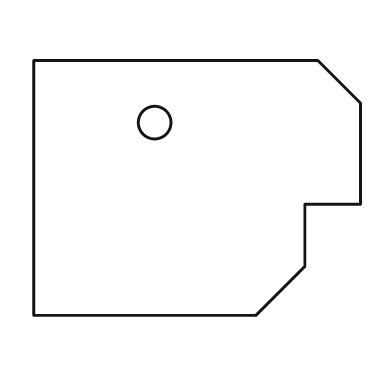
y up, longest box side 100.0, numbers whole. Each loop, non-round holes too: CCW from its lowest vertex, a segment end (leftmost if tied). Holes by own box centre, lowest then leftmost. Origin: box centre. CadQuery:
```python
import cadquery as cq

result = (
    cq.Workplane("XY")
    .moveTo(-50.0, -39.0)
    .lineTo(18.0, -39.0)
    .lineTo(33.0, -24.0)
    .lineTo(33.0, -5.0)
    .lineTo(50.0, -5.0)
    .lineTo(50.0, 26.0)
    .lineTo(37.0, 39.0)
    .lineTo(-50.0, 39.0)
    .close()
    .moveTo(-13.0, 20.0)
    .circle(5.0)
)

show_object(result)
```